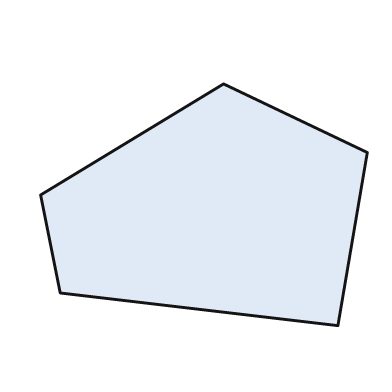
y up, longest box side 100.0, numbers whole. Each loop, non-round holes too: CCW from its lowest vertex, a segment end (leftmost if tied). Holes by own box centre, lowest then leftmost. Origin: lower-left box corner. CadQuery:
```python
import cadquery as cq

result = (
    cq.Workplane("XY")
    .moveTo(91.0, 0.0)
    .lineTo(100.0, 53.0)
    .lineTo(56.0, 74.0)
    .lineTo(0.0, 40.0)
    .lineTo(6.0, 10.0)
    .close()
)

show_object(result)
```